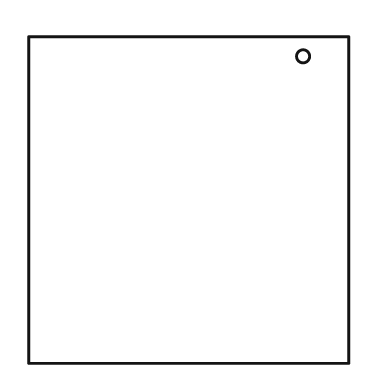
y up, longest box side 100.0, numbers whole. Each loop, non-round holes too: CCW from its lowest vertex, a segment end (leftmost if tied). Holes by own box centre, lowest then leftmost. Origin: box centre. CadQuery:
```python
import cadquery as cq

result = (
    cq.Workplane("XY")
    .moveTo(-49.0, -50.0)
    .lineTo(49.0, -50.0)
    .lineTo(49.0, 50.0)
    .lineTo(-49.0, 50.0)
    .close()
    .moveTo(35.0, 44.0)
    .circle(2.0)
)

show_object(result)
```